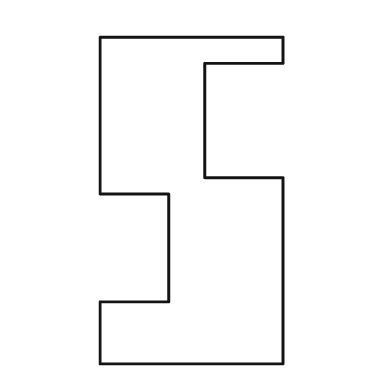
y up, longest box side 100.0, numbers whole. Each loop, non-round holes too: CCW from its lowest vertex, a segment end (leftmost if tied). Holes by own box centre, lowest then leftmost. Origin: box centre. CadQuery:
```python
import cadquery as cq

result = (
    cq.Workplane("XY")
    .moveTo(-28.0, -50.0)
    .lineTo(28.0, -50.0)
    .lineTo(28.0, 7.0)
    .lineTo(4.0, 7.0)
    .lineTo(4.0, 42.0)
    .lineTo(28.0, 42.0)
    .lineTo(28.0, 50.0)
    .lineTo(-28.0, 50.0)
    .lineTo(-28.0, 2.0)
    .lineTo(-7.0, 2.0)
    .lineTo(-7.0, -31.0)
    .lineTo(-28.0, -31.0)
    .close()
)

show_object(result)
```